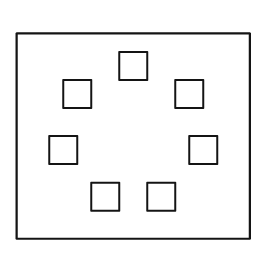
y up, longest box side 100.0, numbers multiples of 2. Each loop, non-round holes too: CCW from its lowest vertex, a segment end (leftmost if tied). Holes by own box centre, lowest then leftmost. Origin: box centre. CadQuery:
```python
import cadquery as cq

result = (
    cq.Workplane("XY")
    .moveTo(-50.0, -44.0)
    .lineTo(50.0, -44.0)
    .lineTo(50.0, 44.0)
    .lineTo(-50.0, 44.0)
    .close()
    .moveTo(-18.0, -32.0)
    .lineTo(-6.0, -32.0)
    .lineTo(-6.0, -20.0)
    .lineTo(-18.0, -20.0)
    .close()
    .moveTo(6.0, -32.0)
    .lineTo(18.0, -32.0)
    .lineTo(18.0, -20.0)
    .lineTo(6.0, -20.0)
    .close()
    .moveTo(-36.0, -12.0)
    .lineTo(-24.0, -12.0)
    .lineTo(-24.0, 0.0)
    .lineTo(-36.0, 0.0)
    .close()
    .moveTo(24.0, -12.0)
    .lineTo(36.0, -12.0)
    .lineTo(36.0, 0.0)
    .lineTo(24.0, 0.0)
    .close()
    .moveTo(-30.0, 12.0)
    .lineTo(-18.0, 12.0)
    .lineTo(-18.0, 24.0)
    .lineTo(-30.0, 24.0)
    .close()
    .moveTo(18.0, 12.0)
    .lineTo(30.0, 12.0)
    .lineTo(30.0, 24.0)
    .lineTo(18.0, 24.0)
    .close()
    .moveTo(-6.0, 24.0)
    .lineTo(6.0, 24.0)
    .lineTo(6.0, 36.0)
    .lineTo(-6.0, 36.0)
    .close()
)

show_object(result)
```